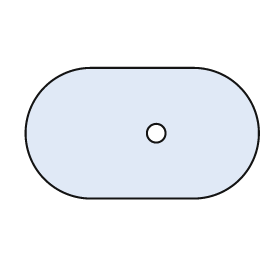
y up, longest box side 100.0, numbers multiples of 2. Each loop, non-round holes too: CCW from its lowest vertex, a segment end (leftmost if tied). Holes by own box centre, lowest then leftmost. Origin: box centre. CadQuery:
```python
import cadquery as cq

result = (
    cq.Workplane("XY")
    .moveTo(-22.0, -28.0)
    .lineTo(22.0, -28.0)
    .threePointArc((50.0, 0.0), (22.0, 28.0))
    .lineTo(-22.0, 28.0)
    .threePointArc((-50.0, 0.0), (-22.0, -28.0))
    .close()
    .moveTo(6.0, 0.0)
    .circle(4.0)
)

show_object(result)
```